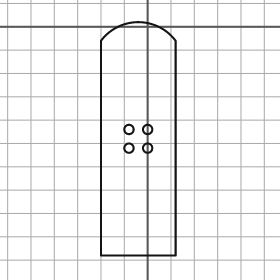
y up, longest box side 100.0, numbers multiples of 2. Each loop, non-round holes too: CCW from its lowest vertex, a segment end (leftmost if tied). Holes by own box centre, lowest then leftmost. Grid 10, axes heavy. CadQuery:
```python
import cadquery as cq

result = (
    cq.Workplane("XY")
    .moveTo(-20.0, -98.0)
    .lineTo(12.0, -98.0)
    .lineTo(12.0, -6.0)
    .threePointArc((-4.0, 2.0), (-20.0, -6.0))
    .close()
    .moveTo(-8.0, -52.0)
    .circle(2.0)
    .moveTo(0.0, -52.0)
    .circle(2.0)
    .moveTo(-8.0, -44.0)
    .circle(2.0)
    .moveTo(0.0, -44.0)
    .circle(2.0)
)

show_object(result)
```